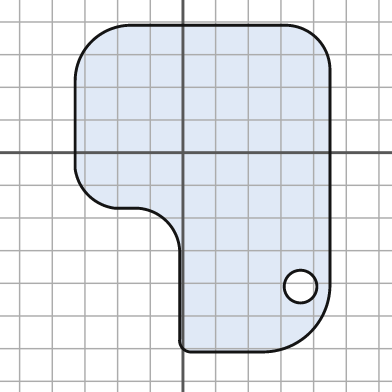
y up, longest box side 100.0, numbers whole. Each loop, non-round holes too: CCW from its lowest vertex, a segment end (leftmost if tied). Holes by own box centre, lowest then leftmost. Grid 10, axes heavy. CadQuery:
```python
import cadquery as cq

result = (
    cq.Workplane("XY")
    .moveTo(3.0, -61.0)
    .lineTo(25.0, -61.0)
    .threePointArc((39.0, -55.0), (45.0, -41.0))
    .lineTo(45.0, 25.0)
    .threePointArc((41.0, 35.0), (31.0, 39.0))
    .lineTo(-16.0, 39.0)
    .threePointArc((-28.0, 34.0), (-33.0, 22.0))
    .lineTo(-33.0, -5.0)
    .threePointArc((-29.0, -13.0), (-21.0, -17.0))
    .lineTo(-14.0, -17.0)
    .threePointArc((-5.0, -21.0), (-1.0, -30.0))
    .lineTo(-1.0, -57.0)
    .threePointArc((0.0, -60.0), (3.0, -61.0))
    .close()
    .moveTo(36.0, -41.0)
    .circle(5.0)
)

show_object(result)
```